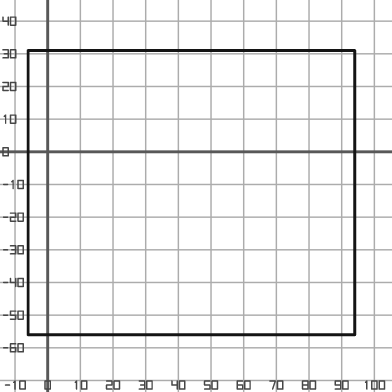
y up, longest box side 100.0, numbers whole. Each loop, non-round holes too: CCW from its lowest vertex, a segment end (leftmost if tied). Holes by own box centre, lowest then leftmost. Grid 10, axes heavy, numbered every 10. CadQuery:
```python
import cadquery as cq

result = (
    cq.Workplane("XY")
    .moveTo(-6.0, -56.0)
    .lineTo(94.0, -56.0)
    .lineTo(94.0, 31.0)
    .lineTo(-6.0, 31.0)
    .close()
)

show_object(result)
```